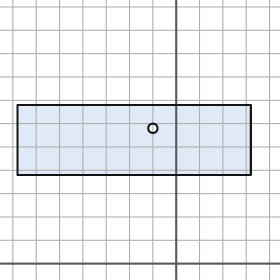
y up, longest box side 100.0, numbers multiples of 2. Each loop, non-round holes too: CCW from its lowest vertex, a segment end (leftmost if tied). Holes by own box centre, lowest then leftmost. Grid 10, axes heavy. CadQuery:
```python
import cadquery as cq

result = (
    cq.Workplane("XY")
    .moveTo(-68.0, 38.0)
    .lineTo(32.0, 38.0)
    .lineTo(32.0, 68.0)
    .lineTo(-68.0, 68.0)
    .close()
    .moveTo(-10.0, 58.0)
    .circle(2.0)
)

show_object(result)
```